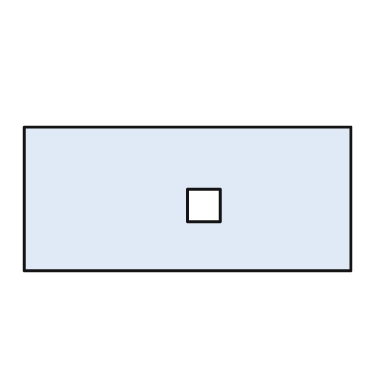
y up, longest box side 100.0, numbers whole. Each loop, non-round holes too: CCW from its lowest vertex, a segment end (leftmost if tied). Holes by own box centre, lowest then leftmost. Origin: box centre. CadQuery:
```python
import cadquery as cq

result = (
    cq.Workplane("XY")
    .moveTo(-50.0, -22.0)
    .lineTo(50.0, -22.0)
    .lineTo(50.0, 22.0)
    .lineTo(-50.0, 22.0)
    .close()
    .moveTo(0.0, -7.0)
    .lineTo(10.0, -7.0)
    .lineTo(10.0, 3.0)
    .lineTo(0.0, 3.0)
    .close()
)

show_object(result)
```